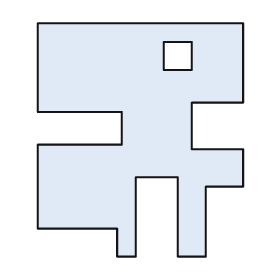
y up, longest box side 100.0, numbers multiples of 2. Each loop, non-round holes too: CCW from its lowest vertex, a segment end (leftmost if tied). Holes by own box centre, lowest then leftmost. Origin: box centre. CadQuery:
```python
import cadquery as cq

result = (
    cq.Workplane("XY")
    .moveTo(-10.0, -50.0)
    .lineTo(-2.0, -50.0)
    .lineTo(-2.0, -16.0)
    .lineTo(16.0, -16.0)
    .lineTo(16.0, -50.0)
    .lineTo(28.0, -50.0)
    .lineTo(28.0, -20.0)
    .lineTo(44.0, -20.0)
    .lineTo(44.0, -4.0)
    .lineTo(22.0, -4.0)
    .lineTo(22.0, 16.0)
    .lineTo(44.0, 16.0)
    .lineTo(44.0, 50.0)
    .lineTo(-44.0, 50.0)
    .lineTo(-44.0, 12.0)
    .lineTo(-8.0, 12.0)
    .lineTo(-8.0, -2.0)
    .lineTo(-44.0, -2.0)
    .lineTo(-44.0, -38.0)
    .lineTo(-10.0, -38.0)
    .close()
    .moveTo(10.0, 30.0)
    .lineTo(22.0, 30.0)
    .lineTo(22.0, 42.0)
    .lineTo(10.0, 42.0)
    .close()
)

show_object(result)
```